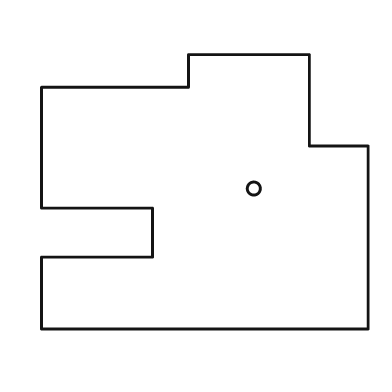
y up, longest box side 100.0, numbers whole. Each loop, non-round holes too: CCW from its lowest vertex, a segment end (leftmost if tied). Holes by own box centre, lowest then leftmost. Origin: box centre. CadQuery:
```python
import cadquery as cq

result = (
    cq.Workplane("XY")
    .moveTo(-50.0, -42.0)
    .lineTo(50.0, -42.0)
    .lineTo(50.0, 14.0)
    .lineTo(32.0, 14.0)
    .lineTo(32.0, 42.0)
    .lineTo(-5.0, 42.0)
    .lineTo(-5.0, 32.0)
    .lineTo(-50.0, 32.0)
    .lineTo(-50.0, -5.0)
    .lineTo(-16.0, -5.0)
    .lineTo(-16.0, -20.0)
    .lineTo(-50.0, -20.0)
    .close()
    .moveTo(15.0, 1.0)
    .circle(2.0)
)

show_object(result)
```